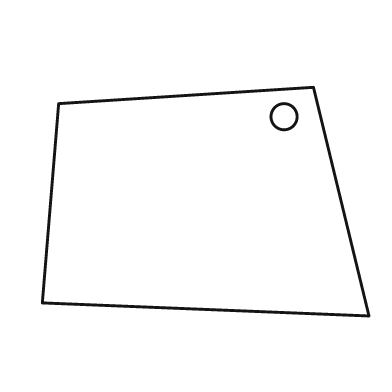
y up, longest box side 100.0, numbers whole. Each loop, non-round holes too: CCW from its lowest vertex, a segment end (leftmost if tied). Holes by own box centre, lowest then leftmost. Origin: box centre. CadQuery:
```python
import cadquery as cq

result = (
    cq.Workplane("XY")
    .moveTo(50.0, -35.0)
    .lineTo(33.0, 35.0)
    .lineTo(-45.0, 30.0)
    .lineTo(-50.0, -31.0)
    .close()
    .moveTo(24.0, 26.0)
    .circle(4.0)
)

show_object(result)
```